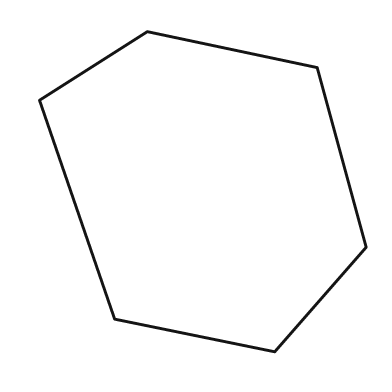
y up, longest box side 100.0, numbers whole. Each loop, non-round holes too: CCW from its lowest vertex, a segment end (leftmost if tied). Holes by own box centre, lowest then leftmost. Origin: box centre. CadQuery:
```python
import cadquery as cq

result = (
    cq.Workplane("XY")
    .moveTo(22.0, -49.0)
    .lineTo(50.0, -17.0)
    .lineTo(35.0, 38.0)
    .lineTo(-17.0, 49.0)
    .lineTo(-50.0, 28.0)
    .lineTo(-27.0, -39.0)
    .close()
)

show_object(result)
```